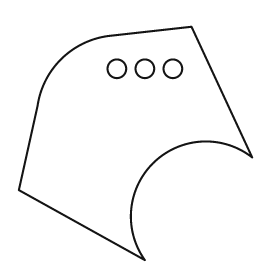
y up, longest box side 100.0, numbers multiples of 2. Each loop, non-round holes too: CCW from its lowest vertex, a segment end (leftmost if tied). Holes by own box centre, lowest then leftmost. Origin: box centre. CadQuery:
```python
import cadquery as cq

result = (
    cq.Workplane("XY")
    .moveTo(4.0, -50.0)
    .threePointArc((8.0, -8.0), (50.0, -6.0))
    .lineTo(24.0, 50.0)
    .lineTo(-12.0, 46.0)
    .threePointArc((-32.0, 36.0), (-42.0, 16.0))
    .lineTo(-50.0, -20.0)
    .close()
    .moveTo(-8.0, 32.0)
    .circle(4.0)
    .moveTo(4.0, 32.0)
    .circle(4.0)
    .moveTo(16.0, 32.0)
    .circle(4.0)
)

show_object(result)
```